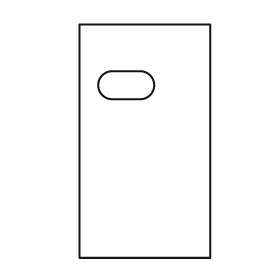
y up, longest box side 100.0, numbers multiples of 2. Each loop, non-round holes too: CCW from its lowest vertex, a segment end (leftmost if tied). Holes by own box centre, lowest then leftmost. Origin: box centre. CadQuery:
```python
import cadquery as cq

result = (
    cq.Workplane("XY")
    .moveTo(-28.0, -50.0)
    .lineTo(28.0, -50.0)
    .lineTo(28.0, 50.0)
    .lineTo(-28.0, 50.0)
    .close()
    .moveTo(-14.0, 18.0)
    .lineTo(-2.0, 18.0)
    .threePointArc((4.0, 24.0), (-2.0, 30.0))
    .lineTo(-14.0, 30.0)
    .threePointArc((-20.0, 24.0), (-14.0, 18.0))
    .close()
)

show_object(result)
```